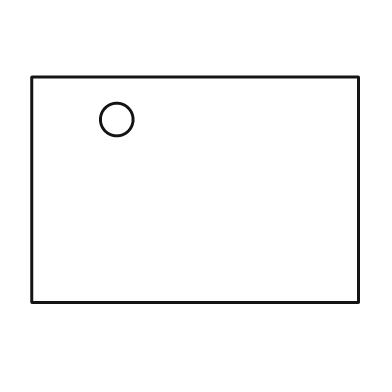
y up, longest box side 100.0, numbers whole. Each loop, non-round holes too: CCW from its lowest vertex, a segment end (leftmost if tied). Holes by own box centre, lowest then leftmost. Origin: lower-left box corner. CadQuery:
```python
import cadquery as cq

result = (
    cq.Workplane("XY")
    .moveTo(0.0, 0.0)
    .lineTo(100.0, 0.0)
    .lineTo(100.0, 69.0)
    .lineTo(0.0, 69.0)
    .close()
    .moveTo(26.0, 56.0)
    .circle(5.0)
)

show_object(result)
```